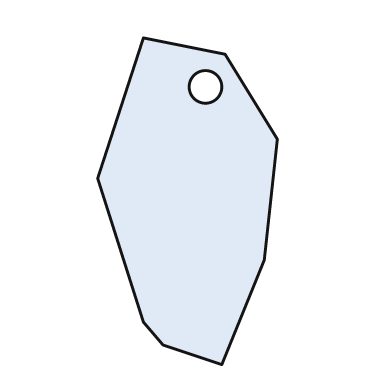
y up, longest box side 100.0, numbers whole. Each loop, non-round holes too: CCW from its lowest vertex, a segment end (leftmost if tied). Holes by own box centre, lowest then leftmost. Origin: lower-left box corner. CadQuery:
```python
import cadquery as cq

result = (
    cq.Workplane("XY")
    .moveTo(38.0, 0.0)
    .lineTo(51.0, 32.0)
    .lineTo(55.0, 69.0)
    .lineTo(39.0, 95.0)
    .lineTo(14.0, 100.0)
    .lineTo(0.0, 57.0)
    .lineTo(14.0, 13.0)
    .lineTo(20.0, 6.0)
    .close()
    .moveTo(33.0, 85.0)
    .circle(5.0)
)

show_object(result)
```